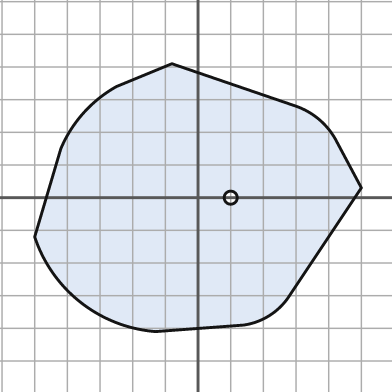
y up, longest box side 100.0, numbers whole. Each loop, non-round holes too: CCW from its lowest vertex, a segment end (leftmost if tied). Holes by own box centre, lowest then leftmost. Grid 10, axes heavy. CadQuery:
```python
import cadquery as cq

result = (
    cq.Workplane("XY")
    .moveTo(-13.0, -41.0)
    .lineTo(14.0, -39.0)
    .threePointArc((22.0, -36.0), (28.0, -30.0))
    .lineTo(50.0, 3.0)
    .lineTo(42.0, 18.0)
    .threePointArc((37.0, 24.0), (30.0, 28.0))
    .lineTo(-8.0, 41.0)
    .lineTo(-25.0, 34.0)
    .threePointArc((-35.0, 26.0), (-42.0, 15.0))
    .lineTo(-50.0, -12.0)
    .threePointArc((-36.0, -32.0), (-13.0, -41.0))
    .close()
    .moveTo(10.0, 0.0)
    .circle(2.0)
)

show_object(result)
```